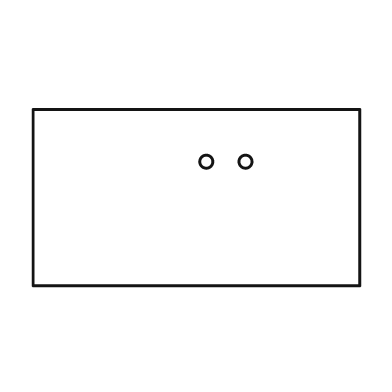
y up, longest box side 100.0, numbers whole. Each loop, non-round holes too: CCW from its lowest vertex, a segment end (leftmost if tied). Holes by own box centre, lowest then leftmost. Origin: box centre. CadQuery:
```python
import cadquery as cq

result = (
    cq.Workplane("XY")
    .moveTo(-50.0, -27.0)
    .lineTo(50.0, -27.0)
    .lineTo(50.0, 27.0)
    .lineTo(-50.0, 27.0)
    .close()
    .moveTo(3.0, 11.0)
    .circle(2.0)
    .moveTo(15.0, 11.0)
    .circle(2.0)
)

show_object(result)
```